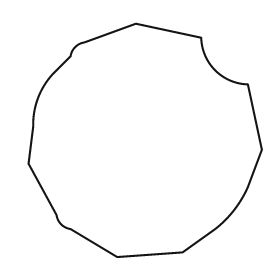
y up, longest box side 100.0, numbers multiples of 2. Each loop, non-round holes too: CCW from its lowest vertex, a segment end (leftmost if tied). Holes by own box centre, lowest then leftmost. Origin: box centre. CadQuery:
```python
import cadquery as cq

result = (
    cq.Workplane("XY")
    .moveTo(-12.0, -50.0)
    .lineTo(16.0, -48.0)
    .lineTo(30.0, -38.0)
    .threePointArc((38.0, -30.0), (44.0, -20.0))
    .lineTo(50.0, -4.0)
    .lineTo(44.0, 24.0)
    .threePointArc((30.0, 30.0), (24.0, 44.0))
    .lineTo(-4.0, 50.0)
    .lineTo(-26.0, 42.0)
    .threePointArc((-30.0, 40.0), (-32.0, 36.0))
    .lineTo(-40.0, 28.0)
    .threePointArc((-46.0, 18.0), (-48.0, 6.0))
    .lineTo(-50.0, -10.0)
    .lineTo(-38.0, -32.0)
    .threePointArc((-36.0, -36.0), (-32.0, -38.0))
    .close()
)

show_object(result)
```